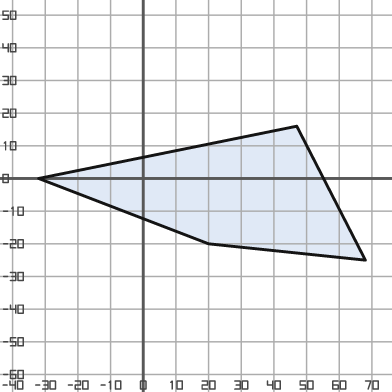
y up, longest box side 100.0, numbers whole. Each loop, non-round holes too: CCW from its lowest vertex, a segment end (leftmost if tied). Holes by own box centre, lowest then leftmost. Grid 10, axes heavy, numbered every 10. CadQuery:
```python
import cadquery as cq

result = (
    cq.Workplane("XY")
    .moveTo(68.0, -25.0)
    .lineTo(47.0, 16.0)
    .lineTo(-32.0, 0.0)
    .lineTo(20.0, -20.0)
    .close()
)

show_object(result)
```